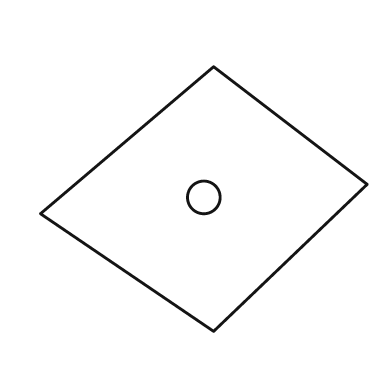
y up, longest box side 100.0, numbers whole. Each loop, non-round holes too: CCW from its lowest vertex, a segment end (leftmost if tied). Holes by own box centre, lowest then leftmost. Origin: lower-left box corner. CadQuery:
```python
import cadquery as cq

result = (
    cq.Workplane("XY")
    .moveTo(53.0, 0.0)
    .lineTo(100.0, 45.0)
    .lineTo(53.0, 81.0)
    .lineTo(0.0, 36.0)
    .close()
    .moveTo(50.0, 41.0)
    .circle(5.0)
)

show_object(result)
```